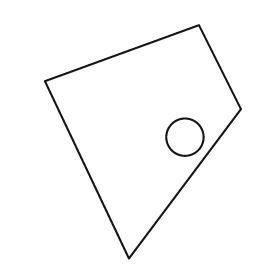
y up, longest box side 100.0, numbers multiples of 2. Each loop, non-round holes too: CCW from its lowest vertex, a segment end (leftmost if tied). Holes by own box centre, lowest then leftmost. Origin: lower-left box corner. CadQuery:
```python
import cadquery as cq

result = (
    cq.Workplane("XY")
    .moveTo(36.0, 0.0)
    .lineTo(84.0, 64.0)
    .lineTo(66.0, 100.0)
    .lineTo(0.0, 76.0)
    .close()
    .moveTo(60.0, 52.0)
    .circle(8.0)
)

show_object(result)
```